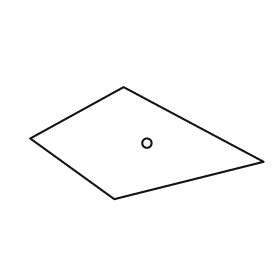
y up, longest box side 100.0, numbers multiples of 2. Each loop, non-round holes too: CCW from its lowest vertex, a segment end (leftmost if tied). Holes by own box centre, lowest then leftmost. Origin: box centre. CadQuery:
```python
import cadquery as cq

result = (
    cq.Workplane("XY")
    .moveTo(-14.0, -24.0)
    .lineTo(50.0, -8.0)
    .lineTo(-10.0, 24.0)
    .lineTo(-50.0, 2.0)
    .close()
    .moveTo(0.0, 0.0)
    .circle(2.0)
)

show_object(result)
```